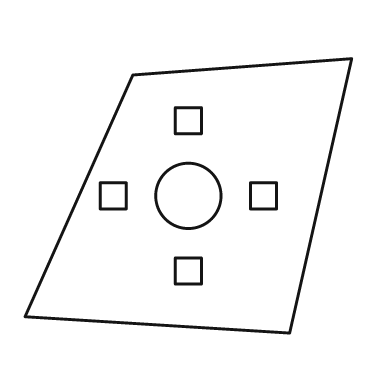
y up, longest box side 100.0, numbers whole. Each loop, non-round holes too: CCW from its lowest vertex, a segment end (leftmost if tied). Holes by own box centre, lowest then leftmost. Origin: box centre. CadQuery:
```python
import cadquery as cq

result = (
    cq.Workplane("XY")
    .moveTo(31.0, -42.0)
    .lineTo(50.0, 42.0)
    .lineTo(-17.0, 37.0)
    .lineTo(-50.0, -37.0)
    .close()
    .moveTo(-4.0, -27.0)
    .lineTo(4.0, -27.0)
    .lineTo(4.0, -19.0)
    .lineTo(-4.0, -19.0)
    .close()
    .moveTo(-27.0, -4.0)
    .lineTo(-19.0, -4.0)
    .lineTo(-19.0, 4.0)
    .lineTo(-27.0, 4.0)
    .close()
    .moveTo(0.0, 0.0)
    .circle(10.0)
    .moveTo(19.0, -4.0)
    .lineTo(27.0, -4.0)
    .lineTo(27.0, 4.0)
    .lineTo(19.0, 4.0)
    .close()
    .moveTo(-4.0, 19.0)
    .lineTo(4.0, 19.0)
    .lineTo(4.0, 27.0)
    .lineTo(-4.0, 27.0)
    .close()
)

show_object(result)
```